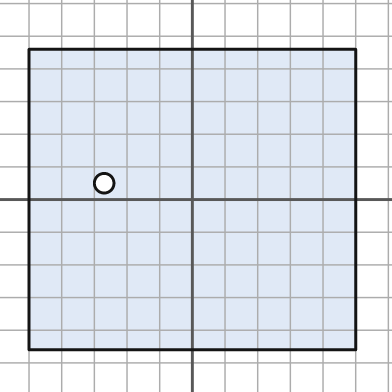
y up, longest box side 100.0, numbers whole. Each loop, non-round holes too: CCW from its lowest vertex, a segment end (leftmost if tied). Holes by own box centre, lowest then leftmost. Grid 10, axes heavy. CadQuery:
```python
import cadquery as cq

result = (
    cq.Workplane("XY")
    .moveTo(-50.0, -46.0)
    .lineTo(50.0, -46.0)
    .lineTo(50.0, 46.0)
    .lineTo(-50.0, 46.0)
    .close()
    .moveTo(-27.0, 5.0)
    .circle(3.0)
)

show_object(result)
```